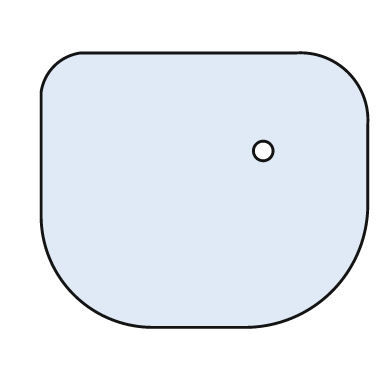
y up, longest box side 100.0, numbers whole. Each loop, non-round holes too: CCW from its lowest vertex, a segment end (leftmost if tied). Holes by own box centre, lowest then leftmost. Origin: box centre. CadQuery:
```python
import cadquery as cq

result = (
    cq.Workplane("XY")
    .moveTo(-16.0, -42.0)
    .lineTo(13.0, -42.0)
    .threePointArc((39.0, -31.0), (50.0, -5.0))
    .lineTo(50.0, 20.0)
    .threePointArc((44.0, 36.0), (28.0, 42.0))
    .lineTo(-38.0, 42.0)
    .threePointArc((-46.0, 38.0), (-50.0, 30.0))
    .lineTo(-50.0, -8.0)
    .threePointArc((-40.0, -32.0), (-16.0, -42.0))
    .close()
    .moveTo(18.0, 12.0)
    .circle(3.0)
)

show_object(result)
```